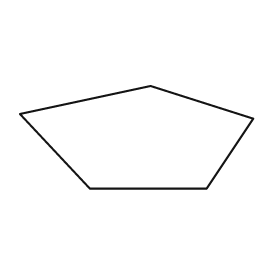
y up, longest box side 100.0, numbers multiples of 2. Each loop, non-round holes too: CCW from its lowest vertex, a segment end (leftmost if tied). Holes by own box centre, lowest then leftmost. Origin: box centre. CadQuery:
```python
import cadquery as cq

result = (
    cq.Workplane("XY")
    .moveTo(-20.0, -22.0)
    .lineTo(30.0, -22.0)
    .lineTo(50.0, 8.0)
    .lineTo(6.0, 22.0)
    .lineTo(-50.0, 10.0)
    .close()
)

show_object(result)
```